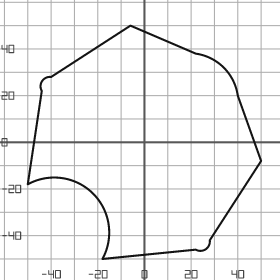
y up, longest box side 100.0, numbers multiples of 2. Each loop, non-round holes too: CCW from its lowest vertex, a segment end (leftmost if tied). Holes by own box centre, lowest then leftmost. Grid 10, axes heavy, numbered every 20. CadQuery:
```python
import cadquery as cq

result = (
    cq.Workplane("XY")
    .moveTo(-18.0, -50.0)
    .lineTo(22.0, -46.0)
    .threePointArc((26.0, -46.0), (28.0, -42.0))
    .lineTo(50.0, -8.0)
    .lineTo(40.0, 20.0)
    .threePointArc((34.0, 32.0), (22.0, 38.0))
    .lineTo(-6.0, 50.0)
    .lineTo(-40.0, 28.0)
    .threePointArc((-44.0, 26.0), (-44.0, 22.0))
    .lineTo(-50.0, -18.0)
    .threePointArc((-22.0, -22.0), (-18.0, -50.0))
    .close()
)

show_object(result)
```